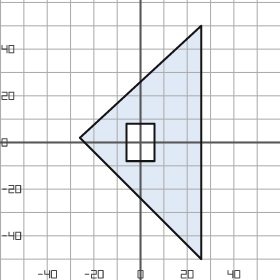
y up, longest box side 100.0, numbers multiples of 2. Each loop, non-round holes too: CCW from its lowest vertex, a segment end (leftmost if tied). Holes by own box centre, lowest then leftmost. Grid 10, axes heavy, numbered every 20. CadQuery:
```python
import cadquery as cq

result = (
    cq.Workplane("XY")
    .moveTo(26.0, -50.0)
    .lineTo(26.0, 50.0)
    .lineTo(-26.0, 2.0)
    .close()
    .moveTo(-6.0, -8.0)
    .lineTo(6.0, -8.0)
    .lineTo(6.0, 8.0)
    .lineTo(-6.0, 8.0)
    .close()
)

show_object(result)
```